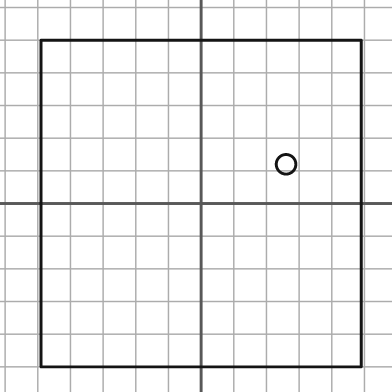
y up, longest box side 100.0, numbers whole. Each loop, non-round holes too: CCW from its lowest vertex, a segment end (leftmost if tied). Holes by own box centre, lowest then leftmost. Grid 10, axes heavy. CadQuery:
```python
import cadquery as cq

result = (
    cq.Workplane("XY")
    .moveTo(-49.0, -50.0)
    .lineTo(49.0, -50.0)
    .lineTo(49.0, 50.0)
    .lineTo(-49.0, 50.0)
    .close()
    .moveTo(26.0, 12.0)
    .circle(3.0)
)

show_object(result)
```